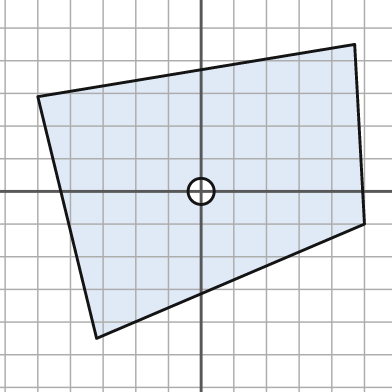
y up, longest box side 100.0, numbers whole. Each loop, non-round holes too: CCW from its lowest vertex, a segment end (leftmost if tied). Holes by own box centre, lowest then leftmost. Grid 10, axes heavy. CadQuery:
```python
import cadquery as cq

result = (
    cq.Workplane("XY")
    .moveTo(-32.0, -45.0)
    .lineTo(50.0, -10.0)
    .lineTo(47.0, 45.0)
    .lineTo(-50.0, 29.0)
    .close()
    .moveTo(0.0, 0.0)
    .circle(4.0)
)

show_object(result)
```